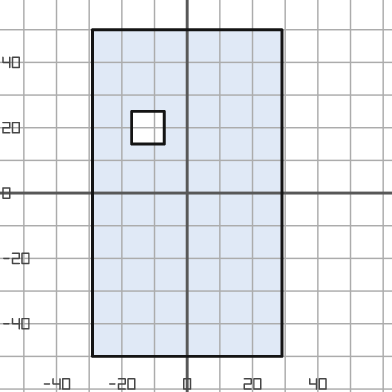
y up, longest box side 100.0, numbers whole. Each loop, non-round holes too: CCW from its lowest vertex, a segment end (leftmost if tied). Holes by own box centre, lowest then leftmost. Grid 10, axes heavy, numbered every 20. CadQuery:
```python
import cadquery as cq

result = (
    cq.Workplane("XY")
    .moveTo(-29.0, -50.0)
    .lineTo(29.0, -50.0)
    .lineTo(29.0, 50.0)
    .lineTo(-29.0, 50.0)
    .close()
    .moveTo(-17.0, 15.0)
    .lineTo(-7.0, 15.0)
    .lineTo(-7.0, 25.0)
    .lineTo(-17.0, 25.0)
    .close()
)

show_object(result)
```